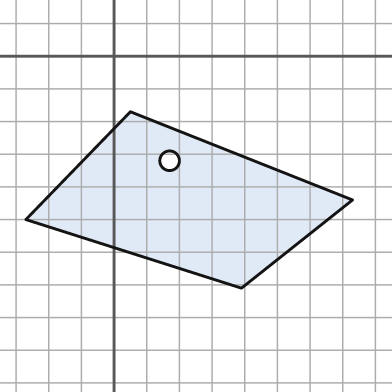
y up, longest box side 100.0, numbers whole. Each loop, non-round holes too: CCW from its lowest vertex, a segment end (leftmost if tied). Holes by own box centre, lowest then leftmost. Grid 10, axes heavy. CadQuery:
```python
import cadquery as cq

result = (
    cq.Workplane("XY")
    .moveTo(39.0, -71.0)
    .lineTo(73.0, -44.0)
    .lineTo(5.0, -17.0)
    .lineTo(-27.0, -50.0)
    .close()
    .moveTo(17.0, -32.0)
    .circle(3.0)
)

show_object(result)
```